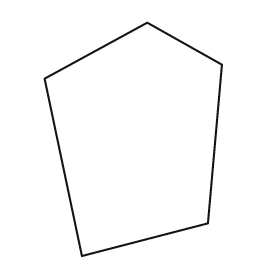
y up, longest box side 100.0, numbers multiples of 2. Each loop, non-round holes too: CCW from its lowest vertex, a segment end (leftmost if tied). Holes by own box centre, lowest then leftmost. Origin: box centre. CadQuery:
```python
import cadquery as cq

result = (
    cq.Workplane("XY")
    .moveTo(-22.0, -50.0)
    .lineTo(32.0, -36.0)
    .lineTo(38.0, 32.0)
    .lineTo(6.0, 50.0)
    .lineTo(-38.0, 26.0)
    .close()
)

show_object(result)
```